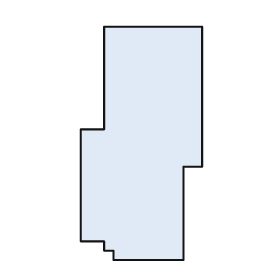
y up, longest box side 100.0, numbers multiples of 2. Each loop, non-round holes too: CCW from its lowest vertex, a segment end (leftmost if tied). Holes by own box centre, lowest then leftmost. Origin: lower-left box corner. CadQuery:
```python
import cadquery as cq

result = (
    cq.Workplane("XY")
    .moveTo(14.0, 0.0)
    .lineTo(44.0, 0.0)
    .lineTo(44.0, 40.0)
    .lineTo(52.0, 40.0)
    .lineTo(52.0, 100.0)
    .lineTo(10.0, 100.0)
    .lineTo(10.0, 56.0)
    .lineTo(0.0, 56.0)
    .lineTo(0.0, 8.0)
    .lineTo(10.0, 8.0)
    .lineTo(10.0, 4.0)
    .lineTo(14.0, 4.0)
    .close()
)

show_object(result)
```